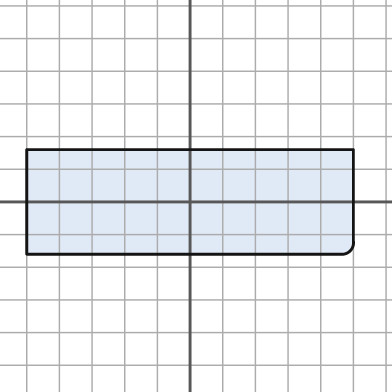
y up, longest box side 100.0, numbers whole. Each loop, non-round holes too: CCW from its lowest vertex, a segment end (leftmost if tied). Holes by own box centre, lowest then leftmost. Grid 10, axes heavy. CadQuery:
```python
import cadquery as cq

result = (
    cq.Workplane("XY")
    .moveTo(-50.0, -16.0)
    .lineTo(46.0, -16.0)
    .threePointArc((49.0, -15.0), (50.0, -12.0))
    .lineTo(50.0, 16.0)
    .lineTo(-50.0, 16.0)
    .close()
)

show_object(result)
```